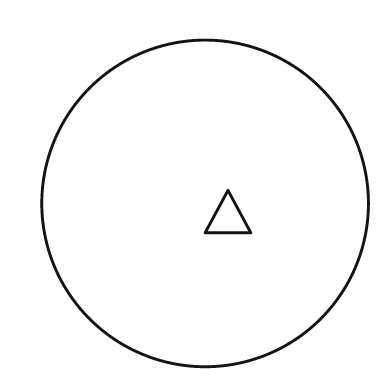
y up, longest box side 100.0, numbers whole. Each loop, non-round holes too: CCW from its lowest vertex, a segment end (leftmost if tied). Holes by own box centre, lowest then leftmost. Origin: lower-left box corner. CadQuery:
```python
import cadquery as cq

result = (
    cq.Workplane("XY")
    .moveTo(50.0, 50.0)
    .circle(50.0)
    .moveTo(50.0, 41.0)
    .lineTo(64.0, 41.0)
    .lineTo(57.0, 54.0)
    .close()
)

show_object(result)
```